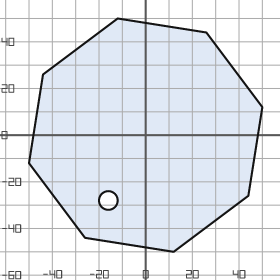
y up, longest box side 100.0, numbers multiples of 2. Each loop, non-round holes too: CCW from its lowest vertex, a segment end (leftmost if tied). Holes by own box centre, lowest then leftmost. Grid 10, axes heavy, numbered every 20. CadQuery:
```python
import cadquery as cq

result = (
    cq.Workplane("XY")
    .moveTo(12.0, -50.0)
    .lineTo(44.0, -26.0)
    .lineTo(50.0, 12.0)
    .lineTo(26.0, 44.0)
    .lineTo(-12.0, 50.0)
    .lineTo(-44.0, 26.0)
    .lineTo(-50.0, -12.0)
    .lineTo(-26.0, -44.0)
    .close()
    .moveTo(-16.0, -28.0)
    .circle(4.0)
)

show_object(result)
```